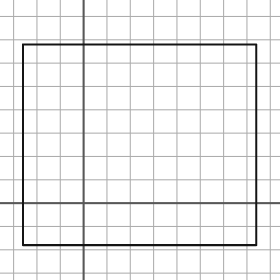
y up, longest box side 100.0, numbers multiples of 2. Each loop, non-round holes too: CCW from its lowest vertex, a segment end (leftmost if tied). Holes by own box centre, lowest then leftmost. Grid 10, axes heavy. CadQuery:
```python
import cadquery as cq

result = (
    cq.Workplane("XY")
    .moveTo(-26.0, -18.0)
    .lineTo(74.0, -18.0)
    .lineTo(74.0, 68.0)
    .lineTo(-26.0, 68.0)
    .close()
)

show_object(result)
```